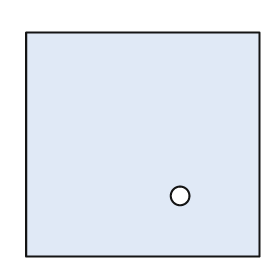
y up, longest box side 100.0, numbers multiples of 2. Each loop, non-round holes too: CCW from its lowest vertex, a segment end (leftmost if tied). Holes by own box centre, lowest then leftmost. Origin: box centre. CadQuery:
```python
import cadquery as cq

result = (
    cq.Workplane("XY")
    .moveTo(-50.0, -48.0)
    .lineTo(50.0, -48.0)
    .lineTo(50.0, 48.0)
    .lineTo(-50.0, 48.0)
    .close()
    .moveTo(16.0, -22.0)
    .circle(4.0)
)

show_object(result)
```